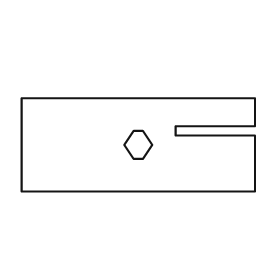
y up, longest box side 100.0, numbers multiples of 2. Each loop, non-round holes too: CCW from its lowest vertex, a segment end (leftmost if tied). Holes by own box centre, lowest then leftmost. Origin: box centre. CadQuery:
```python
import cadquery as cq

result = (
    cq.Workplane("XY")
    .moveTo(-50.0, -20.0)
    .lineTo(50.0, -20.0)
    .lineTo(50.0, 4.0)
    .lineTo(16.0, 4.0)
    .lineTo(16.0, 8.0)
    .lineTo(50.0, 8.0)
    .lineTo(50.0, 20.0)
    .lineTo(-50.0, 20.0)
    .close()
    .moveTo(-2.0, -6.0)
    .lineTo(2.0, -6.0)
    .lineTo(6.0, 0.0)
    .lineTo(2.0, 6.0)
    .lineTo(-2.0, 6.0)
    .lineTo(-6.0, 0.0)
    .close()
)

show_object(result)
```